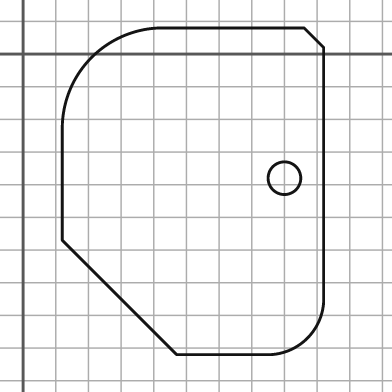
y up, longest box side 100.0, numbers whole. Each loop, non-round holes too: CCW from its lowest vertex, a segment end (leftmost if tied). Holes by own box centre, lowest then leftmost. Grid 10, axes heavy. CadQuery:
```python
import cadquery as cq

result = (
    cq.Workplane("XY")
    .moveTo(47.0, -92.0)
    .lineTo(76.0, -92.0)
    .threePointArc((87.0, -87.0), (92.0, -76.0))
    .lineTo(92.0, 2.0)
    .lineTo(86.0, 8.0)
    .lineTo(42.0, 8.0)
    .threePointArc((21.0, -1.0), (12.0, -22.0))
    .lineTo(12.0, -57.0)
    .close()
    .moveTo(80.0, -38.0)
    .circle(5.0)
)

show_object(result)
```